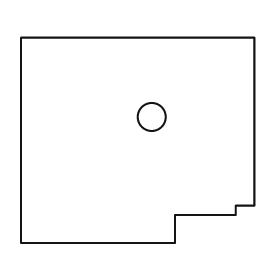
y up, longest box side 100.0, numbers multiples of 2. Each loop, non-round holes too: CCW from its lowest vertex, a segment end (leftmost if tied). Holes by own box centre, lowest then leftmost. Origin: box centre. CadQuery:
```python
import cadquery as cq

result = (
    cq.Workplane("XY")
    .moveTo(-50.0, -44.0)
    .lineTo(16.0, -44.0)
    .lineTo(16.0, -32.0)
    .lineTo(42.0, -32.0)
    .lineTo(42.0, -28.0)
    .lineTo(50.0, -28.0)
    .lineTo(50.0, 44.0)
    .lineTo(-50.0, 44.0)
    .close()
    .moveTo(6.0, 10.0)
    .circle(6.0)
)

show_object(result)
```